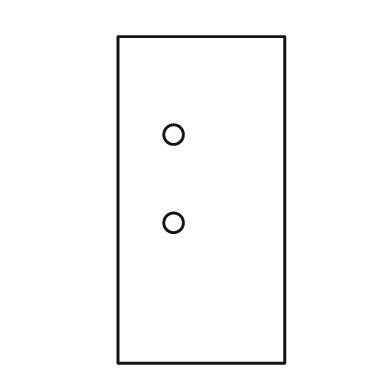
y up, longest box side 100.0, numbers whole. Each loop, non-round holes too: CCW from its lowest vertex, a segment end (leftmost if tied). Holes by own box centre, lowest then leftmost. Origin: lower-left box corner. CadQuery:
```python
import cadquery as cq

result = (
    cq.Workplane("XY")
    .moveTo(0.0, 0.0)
    .lineTo(51.0, 0.0)
    .lineTo(51.0, 100.0)
    .lineTo(0.0, 100.0)
    .close()
    .moveTo(17.0, 43.0)
    .circle(3.0)
    .moveTo(17.0, 70.0)
    .circle(3.0)
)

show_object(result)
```